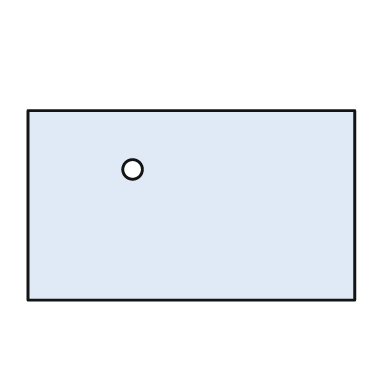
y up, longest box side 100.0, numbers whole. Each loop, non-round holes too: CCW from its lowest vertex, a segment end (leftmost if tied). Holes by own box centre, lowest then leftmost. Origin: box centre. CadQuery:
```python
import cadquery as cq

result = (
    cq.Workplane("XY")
    .moveTo(-50.0, -29.0)
    .lineTo(50.0, -29.0)
    .lineTo(50.0, 29.0)
    .lineTo(-50.0, 29.0)
    .close()
    .moveTo(-18.0, 11.0)
    .circle(3.0)
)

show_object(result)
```